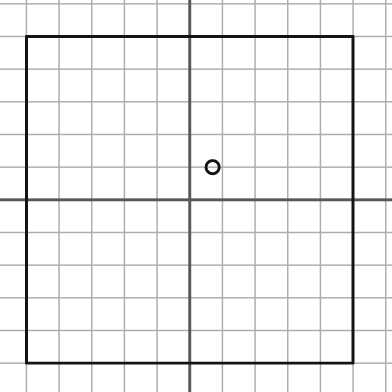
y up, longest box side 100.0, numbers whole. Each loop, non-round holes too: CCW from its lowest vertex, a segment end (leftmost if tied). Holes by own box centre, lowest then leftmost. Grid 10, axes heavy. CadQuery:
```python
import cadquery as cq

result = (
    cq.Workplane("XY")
    .moveTo(-50.0, -50.0)
    .lineTo(50.0, -50.0)
    .lineTo(50.0, 50.0)
    .lineTo(-50.0, 50.0)
    .close()
    .moveTo(7.0, 10.0)
    .circle(2.0)
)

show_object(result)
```